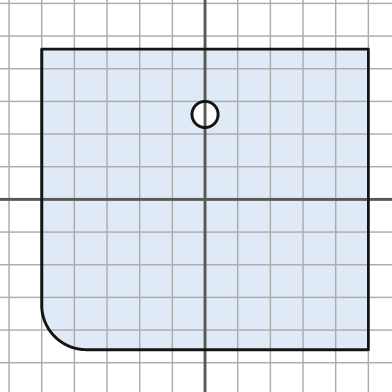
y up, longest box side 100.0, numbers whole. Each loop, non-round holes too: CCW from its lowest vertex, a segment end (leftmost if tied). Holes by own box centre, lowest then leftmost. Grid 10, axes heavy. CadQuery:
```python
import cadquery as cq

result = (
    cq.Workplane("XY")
    .moveTo(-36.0, -46.0)
    .lineTo(50.0, -46.0)
    .lineTo(50.0, 46.0)
    .lineTo(-50.0, 46.0)
    .lineTo(-50.0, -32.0)
    .threePointArc((-46.0, -42.0), (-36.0, -46.0))
    .close()
    .moveTo(0.0, 26.0)
    .circle(4.0)
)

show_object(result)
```